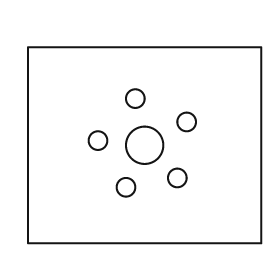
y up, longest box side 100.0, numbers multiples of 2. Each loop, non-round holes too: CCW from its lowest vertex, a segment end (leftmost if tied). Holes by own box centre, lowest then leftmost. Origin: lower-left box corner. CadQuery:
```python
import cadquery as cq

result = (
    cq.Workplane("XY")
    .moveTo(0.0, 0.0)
    .lineTo(100.0, 0.0)
    .lineTo(100.0, 84.0)
    .lineTo(0.0, 84.0)
    .close()
    .moveTo(42.0, 24.0)
    .circle(4.0)
    .moveTo(64.0, 28.0)
    .circle(4.0)
    .moveTo(50.0, 42.0)
    .circle(8.0)
    .moveTo(30.0, 44.0)
    .circle(4.0)
    .moveTo(68.0, 52.0)
    .circle(4.0)
    .moveTo(46.0, 62.0)
    .circle(4.0)
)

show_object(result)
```